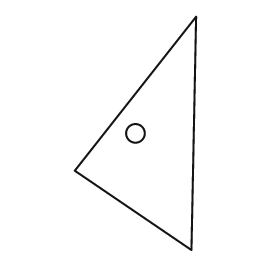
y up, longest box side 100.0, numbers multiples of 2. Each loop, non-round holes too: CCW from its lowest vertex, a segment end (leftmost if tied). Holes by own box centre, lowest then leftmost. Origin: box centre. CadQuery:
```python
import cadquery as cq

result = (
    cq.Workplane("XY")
    .moveTo(24.0, -50.0)
    .lineTo(26.0, 50.0)
    .lineTo(-26.0, -16.0)
    .close()
    .moveTo(0.0, 0.0)
    .circle(4.0)
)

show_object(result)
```